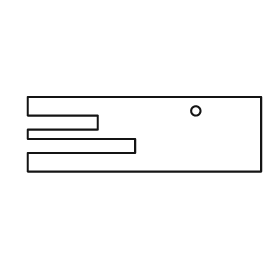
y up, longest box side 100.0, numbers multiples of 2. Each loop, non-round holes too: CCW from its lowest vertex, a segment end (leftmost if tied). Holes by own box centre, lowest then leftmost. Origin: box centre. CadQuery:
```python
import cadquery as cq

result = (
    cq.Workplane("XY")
    .moveTo(-50.0, -16.0)
    .lineTo(50.0, -16.0)
    .lineTo(50.0, 16.0)
    .lineTo(-50.0, 16.0)
    .lineTo(-50.0, 8.0)
    .lineTo(-20.0, 8.0)
    .lineTo(-20.0, 2.0)
    .lineTo(-50.0, 2.0)
    .lineTo(-50.0, -2.0)
    .lineTo(-4.0, -2.0)
    .lineTo(-4.0, -8.0)
    .lineTo(-50.0, -8.0)
    .close()
    .moveTo(22.0, 10.0)
    .circle(2.0)
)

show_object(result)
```